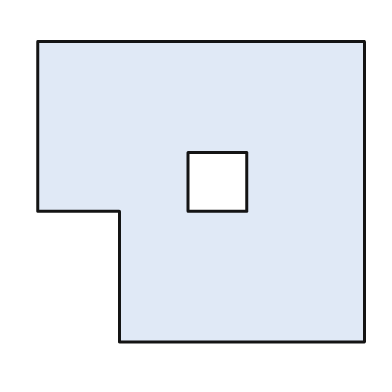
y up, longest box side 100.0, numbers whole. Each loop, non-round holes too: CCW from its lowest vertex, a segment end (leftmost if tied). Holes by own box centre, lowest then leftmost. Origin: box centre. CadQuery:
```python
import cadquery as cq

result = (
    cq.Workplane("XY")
    .moveTo(-25.0, -46.0)
    .lineTo(50.0, -46.0)
    .lineTo(50.0, 46.0)
    .lineTo(-50.0, 46.0)
    .lineTo(-50.0, -6.0)
    .lineTo(-25.0, -6.0)
    .close()
    .moveTo(-4.0, -6.0)
    .lineTo(14.0, -6.0)
    .lineTo(14.0, 12.0)
    .lineTo(-4.0, 12.0)
    .close()
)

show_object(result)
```